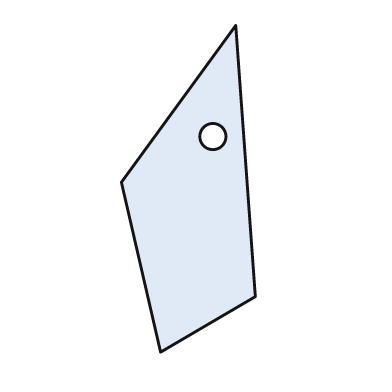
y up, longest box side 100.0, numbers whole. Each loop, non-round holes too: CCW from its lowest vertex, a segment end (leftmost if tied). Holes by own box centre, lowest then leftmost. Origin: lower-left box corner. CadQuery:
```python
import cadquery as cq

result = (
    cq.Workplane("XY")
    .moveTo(12.0, 0.0)
    .lineTo(41.0, 17.0)
    .lineTo(35.0, 100.0)
    .lineTo(0.0, 52.0)
    .close()
    .moveTo(28.0, 66.0)
    .circle(4.0)
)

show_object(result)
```